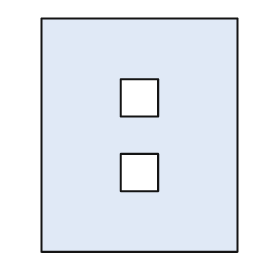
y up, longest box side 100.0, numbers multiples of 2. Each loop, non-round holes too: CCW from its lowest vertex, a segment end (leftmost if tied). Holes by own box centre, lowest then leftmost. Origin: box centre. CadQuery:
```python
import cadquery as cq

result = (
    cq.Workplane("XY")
    .moveTo(-42.0, -50.0)
    .lineTo(42.0, -50.0)
    .lineTo(42.0, 50.0)
    .lineTo(-42.0, 50.0)
    .close()
    .moveTo(-8.0, -24.0)
    .lineTo(8.0, -24.0)
    .lineTo(8.0, -8.0)
    .lineTo(-8.0, -8.0)
    .close()
    .moveTo(-8.0, 8.0)
    .lineTo(8.0, 8.0)
    .lineTo(8.0, 24.0)
    .lineTo(-8.0, 24.0)
    .close()
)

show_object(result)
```